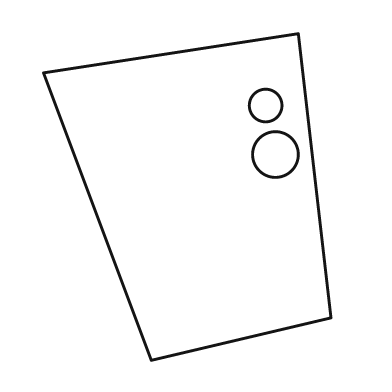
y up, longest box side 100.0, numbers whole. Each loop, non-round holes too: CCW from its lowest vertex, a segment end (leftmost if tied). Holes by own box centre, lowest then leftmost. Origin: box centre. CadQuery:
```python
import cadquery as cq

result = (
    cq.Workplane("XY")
    .moveTo(-11.0, -50.0)
    .lineTo(44.0, -37.0)
    .lineTo(34.0, 50.0)
    .lineTo(-44.0, 38.0)
    .close()
    .moveTo(27.0, 13.0)
    .circle(7.0)
    .moveTo(24.0, 28.0)
    .circle(5.0)
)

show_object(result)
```